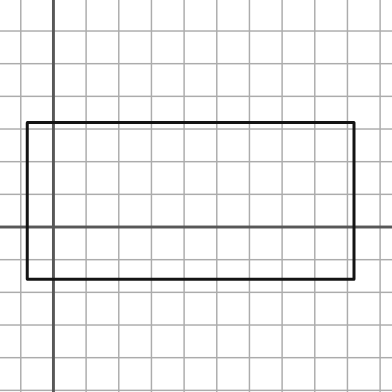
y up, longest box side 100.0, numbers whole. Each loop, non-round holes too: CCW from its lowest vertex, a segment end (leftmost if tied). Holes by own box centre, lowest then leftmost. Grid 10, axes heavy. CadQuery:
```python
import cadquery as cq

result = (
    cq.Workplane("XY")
    .moveTo(-8.0, -16.0)
    .lineTo(92.0, -16.0)
    .lineTo(92.0, 32.0)
    .lineTo(-8.0, 32.0)
    .close()
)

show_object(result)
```